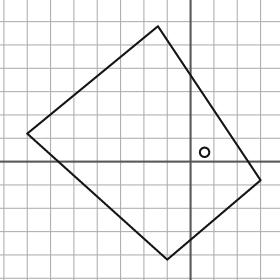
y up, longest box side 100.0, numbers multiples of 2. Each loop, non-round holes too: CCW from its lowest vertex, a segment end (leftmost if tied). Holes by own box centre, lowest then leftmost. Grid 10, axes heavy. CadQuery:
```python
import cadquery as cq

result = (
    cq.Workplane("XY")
    .moveTo(-10.0, -42.0)
    .lineTo(30.0, -8.0)
    .lineTo(-14.0, 58.0)
    .lineTo(-70.0, 12.0)
    .close()
    .moveTo(6.0, 4.0)
    .circle(2.0)
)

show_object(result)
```